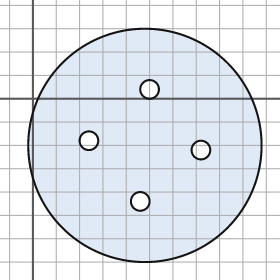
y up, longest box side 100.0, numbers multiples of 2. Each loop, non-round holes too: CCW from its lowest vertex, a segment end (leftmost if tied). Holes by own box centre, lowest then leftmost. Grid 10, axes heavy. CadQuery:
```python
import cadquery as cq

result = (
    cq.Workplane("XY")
    .moveTo(48.0, -20.0)
    .circle(50.0)
    .moveTo(46.0, -44.0)
    .circle(4.0)
    .moveTo(72.0, -22.0)
    .circle(4.0)
    .moveTo(24.0, -18.0)
    .circle(4.0)
    .moveTo(50.0, 4.0)
    .circle(4.0)
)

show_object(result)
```